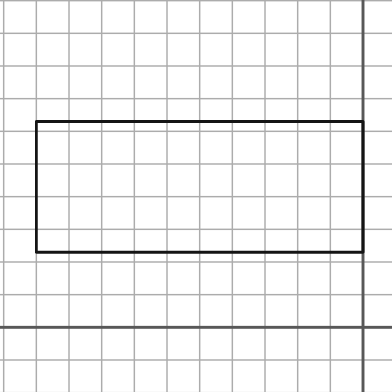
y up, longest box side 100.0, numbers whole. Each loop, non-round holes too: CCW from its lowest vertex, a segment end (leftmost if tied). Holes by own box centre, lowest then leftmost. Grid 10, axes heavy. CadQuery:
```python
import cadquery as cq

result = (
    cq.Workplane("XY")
    .moveTo(-100.0, 23.0)
    .lineTo(0.0, 23.0)
    .lineTo(0.0, 63.0)
    .lineTo(-100.0, 63.0)
    .close()
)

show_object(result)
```